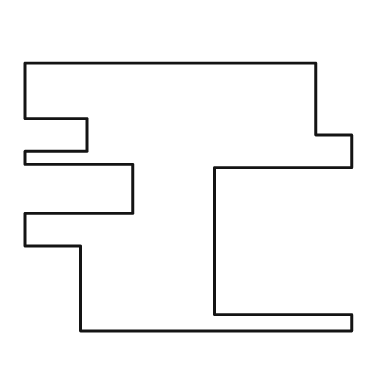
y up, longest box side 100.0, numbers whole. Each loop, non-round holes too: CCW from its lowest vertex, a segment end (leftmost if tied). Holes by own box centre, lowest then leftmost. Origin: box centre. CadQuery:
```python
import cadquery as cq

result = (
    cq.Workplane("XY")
    .moveTo(-33.0, -41.0)
    .lineTo(50.0, -41.0)
    .lineTo(50.0, -36.0)
    .lineTo(8.0, -36.0)
    .lineTo(8.0, 9.0)
    .lineTo(50.0, 9.0)
    .lineTo(50.0, 19.0)
    .lineTo(39.0, 19.0)
    .lineTo(39.0, 41.0)
    .lineTo(-50.0, 41.0)
    .lineTo(-50.0, 24.0)
    .lineTo(-31.0, 24.0)
    .lineTo(-31.0, 14.0)
    .lineTo(-50.0, 14.0)
    .lineTo(-50.0, 10.0)
    .lineTo(-17.0, 10.0)
    .lineTo(-17.0, -5.0)
    .lineTo(-50.0, -5.0)
    .lineTo(-50.0, -15.0)
    .lineTo(-33.0, -15.0)
    .close()
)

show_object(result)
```